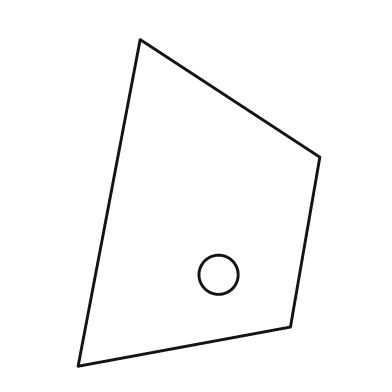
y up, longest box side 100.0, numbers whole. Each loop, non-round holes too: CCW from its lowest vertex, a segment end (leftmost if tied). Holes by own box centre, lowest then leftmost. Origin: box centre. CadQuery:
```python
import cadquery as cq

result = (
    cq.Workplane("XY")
    .moveTo(-37.0, -50.0)
    .lineTo(28.0, -38.0)
    .lineTo(37.0, 14.0)
    .lineTo(-18.0, 50.0)
    .close()
    .moveTo(6.0, -22.0)
    .circle(6.0)
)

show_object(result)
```